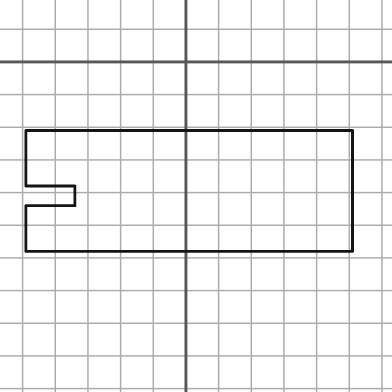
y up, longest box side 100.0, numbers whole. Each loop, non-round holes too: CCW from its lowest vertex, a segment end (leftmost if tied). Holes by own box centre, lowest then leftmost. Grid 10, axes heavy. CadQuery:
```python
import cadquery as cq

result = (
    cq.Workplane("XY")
    .moveTo(-49.0, -58.0)
    .lineTo(51.0, -58.0)
    .lineTo(51.0, -21.0)
    .lineTo(-49.0, -21.0)
    .lineTo(-49.0, -38.0)
    .lineTo(-34.0, -38.0)
    .lineTo(-34.0, -44.0)
    .lineTo(-49.0, -44.0)
    .close()
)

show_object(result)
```